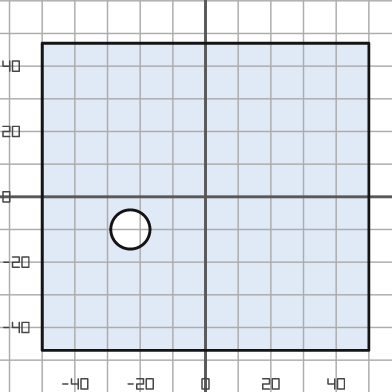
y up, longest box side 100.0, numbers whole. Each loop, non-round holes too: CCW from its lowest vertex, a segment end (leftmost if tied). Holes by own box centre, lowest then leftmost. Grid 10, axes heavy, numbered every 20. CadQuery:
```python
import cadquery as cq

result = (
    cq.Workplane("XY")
    .moveTo(-50.0, -47.0)
    .lineTo(50.0, -47.0)
    .lineTo(50.0, 47.0)
    .lineTo(-50.0, 47.0)
    .close()
    .moveTo(-23.0, -10.0)
    .circle(6.0)
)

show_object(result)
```